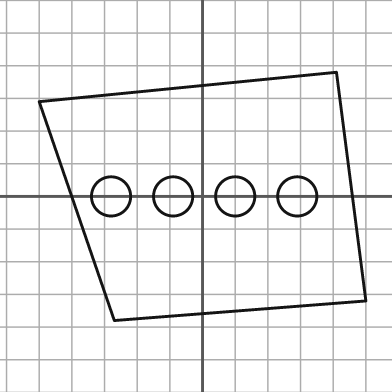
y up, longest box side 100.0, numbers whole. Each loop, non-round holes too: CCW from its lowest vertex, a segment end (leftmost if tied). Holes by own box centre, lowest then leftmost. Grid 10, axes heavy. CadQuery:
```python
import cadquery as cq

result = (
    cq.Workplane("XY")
    .moveTo(-27.0, -38.0)
    .lineTo(50.0, -32.0)
    .lineTo(41.0, 38.0)
    .lineTo(-50.0, 29.0)
    .close()
    .moveTo(-28.0, 0.0)
    .circle(6.0)
    .moveTo(-9.0, 0.0)
    .circle(6.0)
    .moveTo(10.0, 0.0)
    .circle(6.0)
    .moveTo(29.0, 0.0)
    .circle(6.0)
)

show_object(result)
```